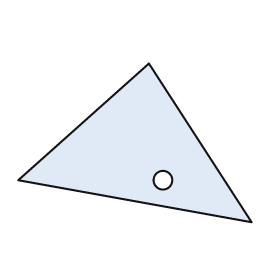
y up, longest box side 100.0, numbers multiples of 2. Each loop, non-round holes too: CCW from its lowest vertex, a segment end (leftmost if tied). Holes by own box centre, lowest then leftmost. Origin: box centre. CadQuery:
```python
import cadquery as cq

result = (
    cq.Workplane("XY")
    .moveTo(50.0, -34.0)
    .lineTo(6.0, 34.0)
    .lineTo(-50.0, -16.0)
    .close()
    .moveTo(12.0, -16.0)
    .circle(4.0)
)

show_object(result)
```